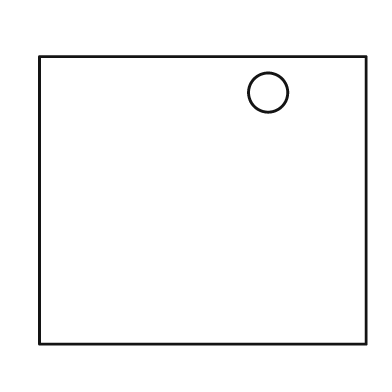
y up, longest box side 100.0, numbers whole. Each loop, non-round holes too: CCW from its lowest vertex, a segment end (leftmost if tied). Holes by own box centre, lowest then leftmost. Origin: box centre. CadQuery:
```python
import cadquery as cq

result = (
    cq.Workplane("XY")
    .moveTo(-50.0, -44.0)
    .lineTo(50.0, -44.0)
    .lineTo(50.0, 44.0)
    .lineTo(-50.0, 44.0)
    .close()
    .moveTo(20.0, 33.0)
    .circle(6.0)
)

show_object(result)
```